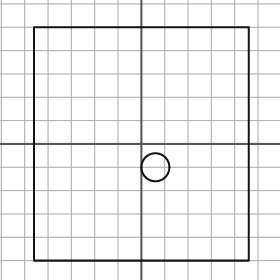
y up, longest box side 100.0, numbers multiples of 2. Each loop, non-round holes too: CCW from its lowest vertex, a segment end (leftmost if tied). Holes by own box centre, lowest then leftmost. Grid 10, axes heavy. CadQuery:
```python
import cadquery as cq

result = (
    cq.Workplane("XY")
    .moveTo(-46.0, -50.0)
    .lineTo(46.0, -50.0)
    .lineTo(46.0, 50.0)
    .lineTo(-46.0, 50.0)
    .close()
    .moveTo(6.0, -10.0)
    .circle(6.0)
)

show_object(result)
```